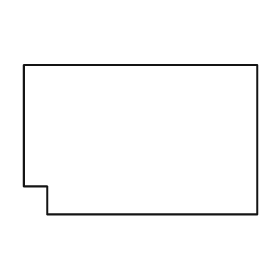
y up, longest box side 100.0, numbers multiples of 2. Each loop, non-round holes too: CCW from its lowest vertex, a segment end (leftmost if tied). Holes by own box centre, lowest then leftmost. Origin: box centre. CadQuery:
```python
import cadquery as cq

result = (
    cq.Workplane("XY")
    .moveTo(-40.0, -32.0)
    .lineTo(50.0, -32.0)
    .lineTo(50.0, 32.0)
    .lineTo(-50.0, 32.0)
    .lineTo(-50.0, -20.0)
    .lineTo(-40.0, -20.0)
    .close()
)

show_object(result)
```